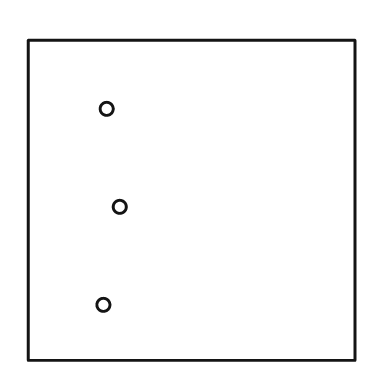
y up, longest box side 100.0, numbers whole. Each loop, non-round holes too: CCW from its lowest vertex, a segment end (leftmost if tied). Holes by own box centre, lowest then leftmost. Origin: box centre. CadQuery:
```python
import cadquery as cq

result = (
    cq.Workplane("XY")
    .moveTo(-50.0, -49.0)
    .lineTo(50.0, -49.0)
    .lineTo(50.0, 49.0)
    .lineTo(-50.0, 49.0)
    .close()
    .moveTo(-27.0, -32.0)
    .circle(2.0)
    .moveTo(-22.0, -2.0)
    .circle(2.0)
    .moveTo(-26.0, 28.0)
    .circle(2.0)
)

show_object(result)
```